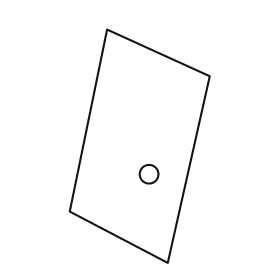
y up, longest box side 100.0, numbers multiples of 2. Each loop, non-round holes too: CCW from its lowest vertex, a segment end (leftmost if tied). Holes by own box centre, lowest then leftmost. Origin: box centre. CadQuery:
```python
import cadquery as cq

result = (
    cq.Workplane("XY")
    .moveTo(12.0, -50.0)
    .lineTo(30.0, 30.0)
    .lineTo(-14.0, 50.0)
    .lineTo(-30.0, -28.0)
    .close()
    .moveTo(4.0, -12.0)
    .circle(4.0)
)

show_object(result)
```